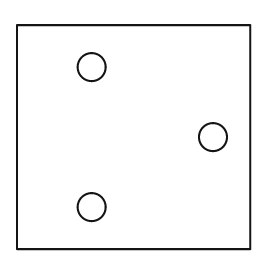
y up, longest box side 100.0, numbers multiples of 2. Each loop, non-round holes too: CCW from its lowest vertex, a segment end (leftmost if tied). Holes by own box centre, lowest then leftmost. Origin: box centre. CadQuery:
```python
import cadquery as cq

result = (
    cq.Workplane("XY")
    .moveTo(-50.0, -48.0)
    .lineTo(50.0, -48.0)
    .lineTo(50.0, 48.0)
    .lineTo(-50.0, 48.0)
    .close()
    .moveTo(-18.0, -30.0)
    .circle(6.0)
    .moveTo(34.0, 0.0)
    .circle(6.0)
    .moveTo(-18.0, 30.0)
    .circle(6.0)
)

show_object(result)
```